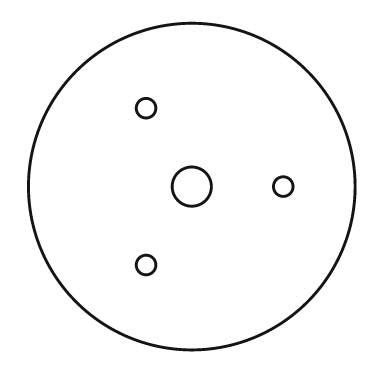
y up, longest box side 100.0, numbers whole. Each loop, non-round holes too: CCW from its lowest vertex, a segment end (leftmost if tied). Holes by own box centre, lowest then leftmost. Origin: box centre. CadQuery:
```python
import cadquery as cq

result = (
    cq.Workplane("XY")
    .moveTo(0.0, 0.0)
    .circle(50.0)
    .moveTo(-14.0, -24.0)
    .circle(3.0)
    .moveTo(0.0, 0.0)
    .circle(6.0)
    .moveTo(28.0, 0.0)
    .circle(3.0)
    .moveTo(-14.0, 24.0)
    .circle(3.0)
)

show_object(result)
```